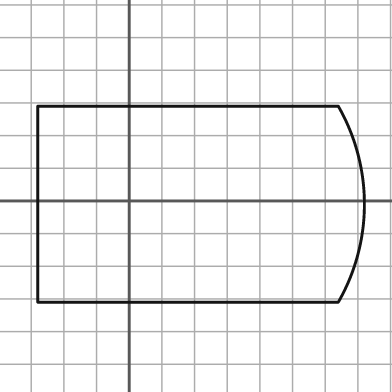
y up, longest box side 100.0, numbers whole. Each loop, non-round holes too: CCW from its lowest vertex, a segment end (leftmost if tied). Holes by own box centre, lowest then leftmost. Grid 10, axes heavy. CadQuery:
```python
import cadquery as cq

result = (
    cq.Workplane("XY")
    .moveTo(-28.0, -31.0)
    .lineTo(64.0, -31.0)
    .threePointArc((72.0, -1.0), (64.0, 29.0))
    .lineTo(-28.0, 29.0)
    .close()
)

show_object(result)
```